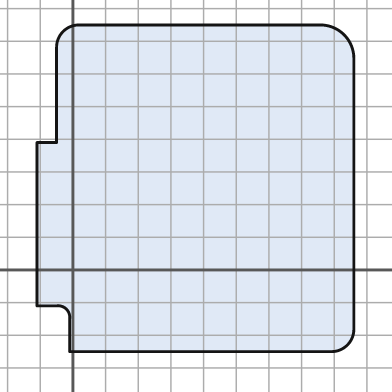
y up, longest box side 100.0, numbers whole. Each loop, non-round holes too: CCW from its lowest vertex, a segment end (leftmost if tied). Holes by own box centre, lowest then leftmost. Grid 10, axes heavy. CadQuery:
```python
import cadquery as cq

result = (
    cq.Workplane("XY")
    .moveTo(-1.0, -25.0)
    .lineTo(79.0, -25.0)
    .threePointArc((84.0, -23.0), (86.0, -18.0))
    .lineTo(86.0, 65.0)
    .threePointArc((83.0, 72.0), (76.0, 75.0))
    .lineTo(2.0, 75.0)
    .threePointArc((-3.0, 73.0), (-5.0, 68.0))
    .lineTo(-5.0, 39.0)
    .lineTo(-11.0, 39.0)
    .lineTo(-11.0, -11.0)
    .lineTo(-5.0, -11.0)
    .threePointArc((-2.0, -12.0), (-1.0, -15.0))
    .close()
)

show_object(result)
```